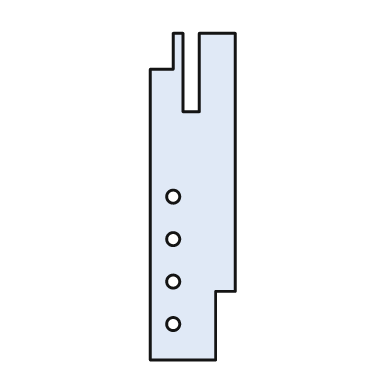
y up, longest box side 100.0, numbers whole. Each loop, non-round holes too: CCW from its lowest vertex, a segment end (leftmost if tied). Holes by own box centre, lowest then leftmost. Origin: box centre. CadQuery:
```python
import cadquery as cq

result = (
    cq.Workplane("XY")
    .moveTo(-13.0, -50.0)
    .lineTo(7.0, -50.0)
    .lineTo(7.0, -29.0)
    .lineTo(13.0, -29.0)
    .lineTo(13.0, 50.0)
    .lineTo(2.0, 50.0)
    .lineTo(2.0, 26.0)
    .lineTo(-3.0, 26.0)
    .lineTo(-3.0, 50.0)
    .lineTo(-6.0, 50.0)
    .lineTo(-6.0, 39.0)
    .lineTo(-13.0, 39.0)
    .close()
    .moveTo(-6.0, -39.0)
    .circle(2.0)
    .moveTo(-6.0, -26.0)
    .circle(2.0)
    .moveTo(-6.0, -13.0)
    .circle(2.0)
    .moveTo(-6.0, 0.0)
    .circle(2.0)
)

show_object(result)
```